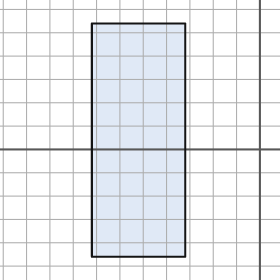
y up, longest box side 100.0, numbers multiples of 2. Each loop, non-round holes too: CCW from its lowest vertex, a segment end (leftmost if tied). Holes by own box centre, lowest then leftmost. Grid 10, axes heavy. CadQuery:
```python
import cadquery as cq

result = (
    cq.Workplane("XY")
    .moveTo(-72.0, -46.0)
    .lineTo(-32.0, -46.0)
    .lineTo(-32.0, 54.0)
    .lineTo(-72.0, 54.0)
    .close()
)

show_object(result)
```